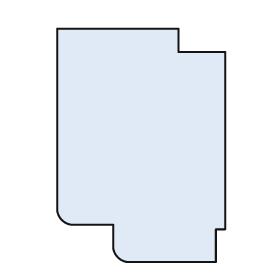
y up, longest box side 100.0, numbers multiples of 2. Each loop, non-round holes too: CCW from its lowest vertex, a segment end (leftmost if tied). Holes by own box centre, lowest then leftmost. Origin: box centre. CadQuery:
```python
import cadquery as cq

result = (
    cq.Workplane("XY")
    .moveTo(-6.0, -50.0)
    .lineTo(32.0, -50.0)
    .lineTo(32.0, -36.0)
    .lineTo(36.0, -36.0)
    .lineTo(36.0, 40.0)
    .lineTo(16.0, 40.0)
    .lineTo(16.0, 50.0)
    .lineTo(-36.0, 50.0)
    .lineTo(-36.0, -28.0)
    .threePointArc((-34.0, -32.0), (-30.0, -34.0))
    .lineTo(-12.0, -34.0)
    .lineTo(-12.0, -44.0)
    .threePointArc((-10.0, -48.0), (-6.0, -50.0))
    .close()
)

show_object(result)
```